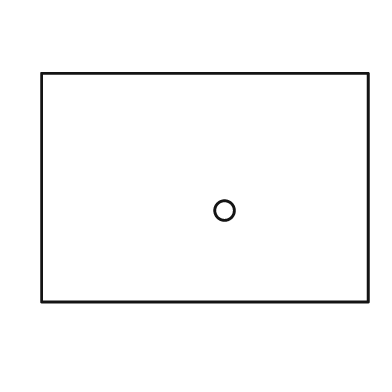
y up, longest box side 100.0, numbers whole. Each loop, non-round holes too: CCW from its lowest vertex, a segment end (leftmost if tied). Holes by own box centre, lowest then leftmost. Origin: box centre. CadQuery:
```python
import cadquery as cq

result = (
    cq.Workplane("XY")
    .moveTo(-50.0, -35.0)
    .lineTo(50.0, -35.0)
    .lineTo(50.0, 35.0)
    .lineTo(-50.0, 35.0)
    .close()
    .moveTo(6.0, -7.0)
    .circle(3.0)
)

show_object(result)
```